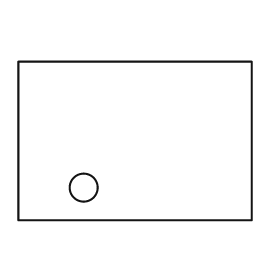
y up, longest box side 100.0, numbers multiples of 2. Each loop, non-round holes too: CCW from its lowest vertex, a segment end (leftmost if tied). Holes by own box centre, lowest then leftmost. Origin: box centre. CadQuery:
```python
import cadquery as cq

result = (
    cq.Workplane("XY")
    .moveTo(-50.0, -34.0)
    .lineTo(50.0, -34.0)
    .lineTo(50.0, 34.0)
    .lineTo(-50.0, 34.0)
    .close()
    .moveTo(-22.0, -20.0)
    .circle(6.0)
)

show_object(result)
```